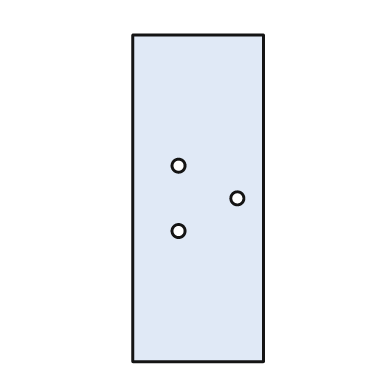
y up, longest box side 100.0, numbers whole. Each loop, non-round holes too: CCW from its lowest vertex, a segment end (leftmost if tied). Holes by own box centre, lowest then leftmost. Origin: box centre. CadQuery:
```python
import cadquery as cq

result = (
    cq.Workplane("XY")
    .moveTo(-20.0, -50.0)
    .lineTo(20.0, -50.0)
    .lineTo(20.0, 50.0)
    .lineTo(-20.0, 50.0)
    .close()
    .moveTo(-6.0, -10.0)
    .circle(2.0)
    .moveTo(12.0, 0.0)
    .circle(2.0)
    .moveTo(-6.0, 10.0)
    .circle(2.0)
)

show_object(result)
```